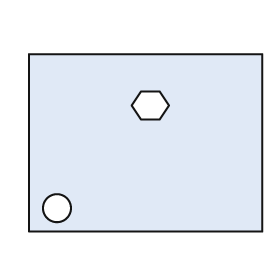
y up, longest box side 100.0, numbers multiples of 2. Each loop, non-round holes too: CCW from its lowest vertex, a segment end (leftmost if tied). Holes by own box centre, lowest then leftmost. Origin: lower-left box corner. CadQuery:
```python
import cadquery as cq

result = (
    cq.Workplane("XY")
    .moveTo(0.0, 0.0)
    .lineTo(100.0, 0.0)
    .lineTo(100.0, 76.0)
    .lineTo(0.0, 76.0)
    .close()
    .moveTo(12.0, 10.0)
    .circle(6.0)
    .moveTo(48.0, 48.0)
    .lineTo(56.0, 48.0)
    .lineTo(60.0, 54.0)
    .lineTo(56.0, 60.0)
    .lineTo(48.0, 60.0)
    .lineTo(44.0, 54.0)
    .close()
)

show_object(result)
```